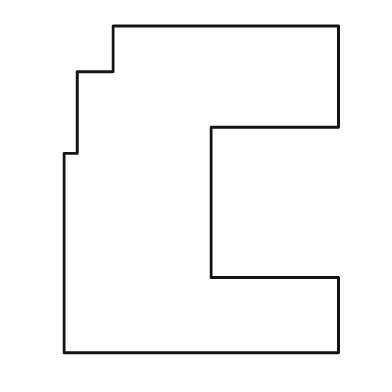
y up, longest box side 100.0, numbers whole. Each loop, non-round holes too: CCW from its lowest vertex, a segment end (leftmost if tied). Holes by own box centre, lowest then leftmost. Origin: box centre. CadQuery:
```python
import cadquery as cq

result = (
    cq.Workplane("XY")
    .moveTo(-42.0, -50.0)
    .lineTo(42.0, -50.0)
    .lineTo(42.0, -27.0)
    .lineTo(3.0, -27.0)
    .lineTo(3.0, 19.0)
    .lineTo(42.0, 19.0)
    .lineTo(42.0, 50.0)
    .lineTo(-27.0, 50.0)
    .lineTo(-27.0, 36.0)
    .lineTo(-38.0, 36.0)
    .lineTo(-38.0, 11.0)
    .lineTo(-42.0, 11.0)
    .close()
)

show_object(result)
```